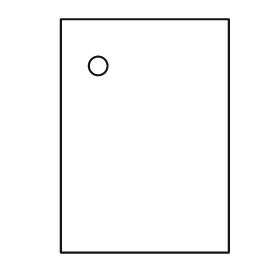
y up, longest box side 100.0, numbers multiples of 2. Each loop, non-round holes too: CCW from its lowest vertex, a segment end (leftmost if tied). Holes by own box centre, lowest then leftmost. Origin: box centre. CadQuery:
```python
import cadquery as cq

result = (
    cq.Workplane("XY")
    .moveTo(-36.0, -50.0)
    .lineTo(36.0, -50.0)
    .lineTo(36.0, 50.0)
    .lineTo(-36.0, 50.0)
    .close()
    .moveTo(-20.0, 30.0)
    .circle(4.0)
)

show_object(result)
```